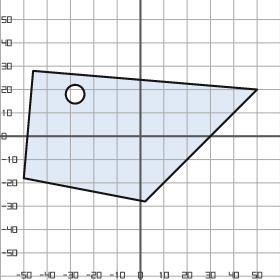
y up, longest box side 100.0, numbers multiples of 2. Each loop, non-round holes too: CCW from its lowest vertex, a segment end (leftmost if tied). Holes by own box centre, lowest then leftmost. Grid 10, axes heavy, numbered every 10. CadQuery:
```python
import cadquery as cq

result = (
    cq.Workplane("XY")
    .moveTo(2.0, -28.0)
    .lineTo(50.0, 20.0)
    .lineTo(-46.0, 28.0)
    .lineTo(-50.0, -18.0)
    .close()
    .moveTo(-28.0, 18.0)
    .circle(4.0)
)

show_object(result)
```